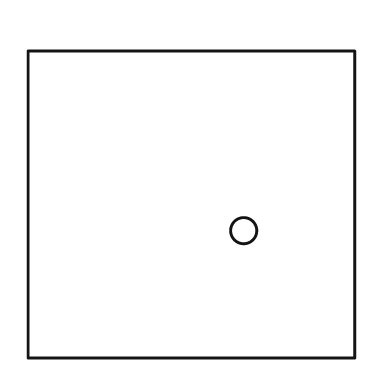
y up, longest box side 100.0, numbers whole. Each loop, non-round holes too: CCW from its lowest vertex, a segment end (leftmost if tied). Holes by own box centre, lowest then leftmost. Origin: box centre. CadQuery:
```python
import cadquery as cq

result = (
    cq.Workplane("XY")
    .moveTo(-50.0, -47.0)
    .lineTo(50.0, -47.0)
    .lineTo(50.0, 47.0)
    .lineTo(-50.0, 47.0)
    .close()
    .moveTo(16.0, -8.0)
    .circle(4.0)
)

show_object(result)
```